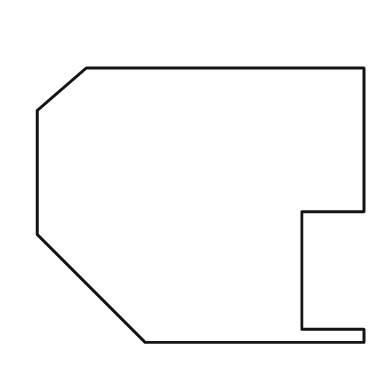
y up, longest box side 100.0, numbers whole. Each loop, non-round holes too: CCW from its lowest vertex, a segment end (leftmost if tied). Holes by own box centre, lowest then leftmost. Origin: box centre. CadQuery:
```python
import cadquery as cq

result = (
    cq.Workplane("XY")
    .moveTo(-17.0, -42.0)
    .lineTo(50.0, -42.0)
    .lineTo(50.0, -38.0)
    .lineTo(31.0, -38.0)
    .lineTo(31.0, -2.0)
    .lineTo(50.0, -2.0)
    .lineTo(50.0, 42.0)
    .lineTo(-35.0, 42.0)
    .lineTo(-50.0, 29.0)
    .lineTo(-50.0, -9.0)
    .close()
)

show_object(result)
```